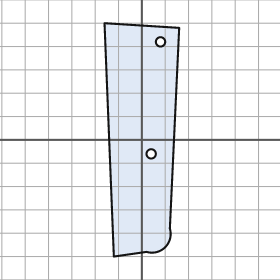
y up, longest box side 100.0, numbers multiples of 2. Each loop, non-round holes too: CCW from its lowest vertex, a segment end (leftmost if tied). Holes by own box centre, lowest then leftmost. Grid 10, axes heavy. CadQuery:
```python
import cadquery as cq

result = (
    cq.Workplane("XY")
    .moveTo(-12.0, -50.0)
    .lineTo(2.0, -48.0)
    .threePointArc((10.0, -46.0), (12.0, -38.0))
    .lineTo(16.0, 48.0)
    .lineTo(-16.0, 50.0)
    .close()
    .moveTo(4.0, -6.0)
    .circle(2.0)
    .moveTo(8.0, 42.0)
    .circle(2.0)
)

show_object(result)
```